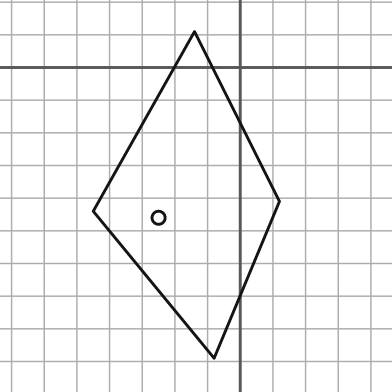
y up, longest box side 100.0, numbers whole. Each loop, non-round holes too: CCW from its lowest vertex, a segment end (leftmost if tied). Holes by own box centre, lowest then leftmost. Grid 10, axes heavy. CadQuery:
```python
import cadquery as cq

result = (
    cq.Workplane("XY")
    .moveTo(-8.0, -89.0)
    .lineTo(12.0, -41.0)
    .lineTo(-14.0, 11.0)
    .lineTo(-45.0, -44.0)
    .close()
    .moveTo(-25.0, -46.0)
    .circle(2.0)
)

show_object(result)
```